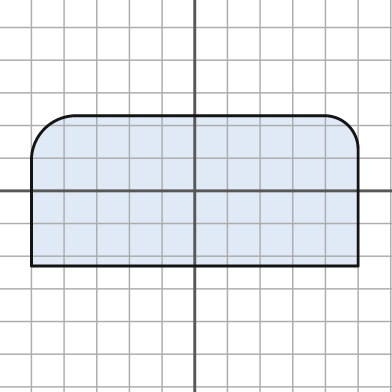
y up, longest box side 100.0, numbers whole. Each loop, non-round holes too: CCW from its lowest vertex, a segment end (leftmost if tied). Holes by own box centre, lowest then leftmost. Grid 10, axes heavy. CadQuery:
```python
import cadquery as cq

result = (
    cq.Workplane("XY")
    .moveTo(-50.0, -23.0)
    .lineTo(50.0, -23.0)
    .lineTo(50.0, 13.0)
    .threePointArc((47.0, 20.0), (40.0, 23.0))
    .lineTo(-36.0, 23.0)
    .threePointArc((-46.0, 19.0), (-50.0, 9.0))
    .close()
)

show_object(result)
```